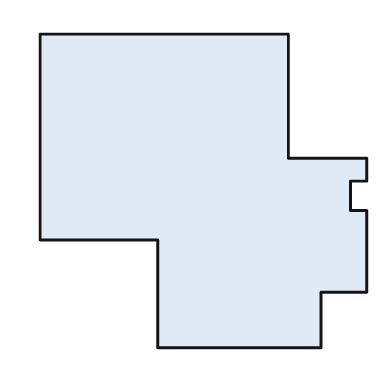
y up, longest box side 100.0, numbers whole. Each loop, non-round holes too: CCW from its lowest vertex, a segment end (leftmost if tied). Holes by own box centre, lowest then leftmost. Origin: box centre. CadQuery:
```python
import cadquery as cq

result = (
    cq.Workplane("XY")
    .moveTo(-14.0, -48.0)
    .lineTo(36.0, -48.0)
    .lineTo(36.0, -31.0)
    .lineTo(50.0, -31.0)
    .lineTo(50.0, -6.0)
    .lineTo(45.0, -6.0)
    .lineTo(45.0, 3.0)
    .lineTo(50.0, 3.0)
    .lineTo(50.0, 10.0)
    .lineTo(26.0, 10.0)
    .lineTo(26.0, 48.0)
    .lineTo(-50.0, 48.0)
    .lineTo(-50.0, -15.0)
    .lineTo(-14.0, -15.0)
    .close()
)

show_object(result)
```